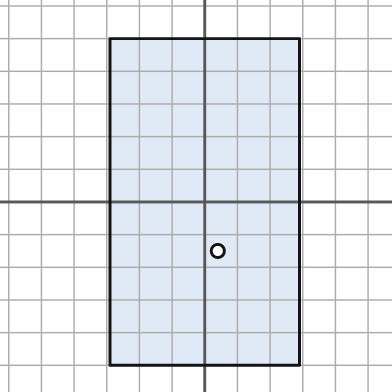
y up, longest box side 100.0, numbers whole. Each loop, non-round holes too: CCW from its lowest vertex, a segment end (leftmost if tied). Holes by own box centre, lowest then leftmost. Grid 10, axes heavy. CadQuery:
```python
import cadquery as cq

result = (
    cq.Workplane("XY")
    .moveTo(-29.0, -50.0)
    .lineTo(29.0, -50.0)
    .lineTo(29.0, 50.0)
    .lineTo(-29.0, 50.0)
    .close()
    .moveTo(4.0, -15.0)
    .circle(2.0)
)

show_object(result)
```